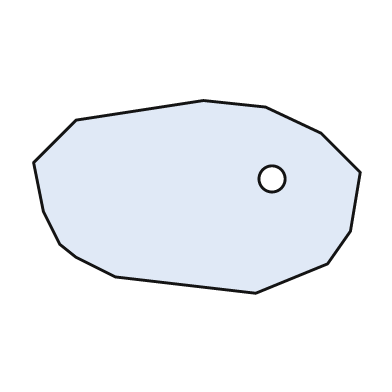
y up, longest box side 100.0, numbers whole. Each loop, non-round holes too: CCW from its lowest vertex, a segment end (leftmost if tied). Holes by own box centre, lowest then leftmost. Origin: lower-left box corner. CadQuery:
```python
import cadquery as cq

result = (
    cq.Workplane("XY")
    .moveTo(68.0, 0.0)
    .lineTo(90.0, 9.0)
    .lineTo(97.0, 19.0)
    .lineTo(100.0, 37.0)
    .lineTo(88.0, 49.0)
    .lineTo(71.0, 57.0)
    .lineTo(52.0, 59.0)
    .lineTo(13.0, 53.0)
    .lineTo(0.0, 40.0)
    .lineTo(3.0, 25.0)
    .lineTo(8.0, 15.0)
    .lineTo(13.0, 11.0)
    .lineTo(25.0, 5.0)
    .close()
    .moveTo(73.0, 35.0)
    .circle(4.0)
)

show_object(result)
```